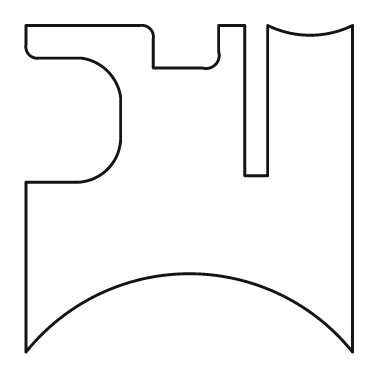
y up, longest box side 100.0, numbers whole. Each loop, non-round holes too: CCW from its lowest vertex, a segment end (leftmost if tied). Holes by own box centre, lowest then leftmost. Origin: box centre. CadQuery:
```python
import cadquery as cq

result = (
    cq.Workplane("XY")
    .moveTo(-50.0, -50.0)
    .threePointArc((0.0, -26.0), (50.0, -50.0))
    .lineTo(50.0, 50.0)
    .threePointArc((37.0, 47.0), (24.0, 50.0))
    .lineTo(24.0, 4.0)
    .lineTo(17.0, 4.0)
    .lineTo(17.0, 50.0)
    .lineTo(9.0, 50.0)
    .lineTo(9.0, 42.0)
    .threePointArc((8.0, 38.0), (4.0, 37.0))
    .lineTo(-11.0, 37.0)
    .lineTo(-11.0, 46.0)
    .threePointArc((-12.0, 49.0), (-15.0, 50.0))
    .lineTo(-50.0, 50.0)
    .lineTo(-50.0, 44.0)
    .threePointArc((-49.0, 41.0), (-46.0, 40.0))
    .lineTo(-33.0, 40.0)
    .threePointArc((-25.0, 36.0), (-21.0, 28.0))
    .lineTo(-21.0, 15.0)
    .threePointArc((-25.0, 6.0), (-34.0, 2.0))
    .lineTo(-50.0, 2.0)
    .close()
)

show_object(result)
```